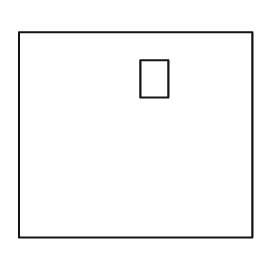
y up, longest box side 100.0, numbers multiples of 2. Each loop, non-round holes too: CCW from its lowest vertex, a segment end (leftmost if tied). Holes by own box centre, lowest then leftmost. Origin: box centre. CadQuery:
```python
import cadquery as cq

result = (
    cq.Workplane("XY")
    .moveTo(-50.0, -44.0)
    .lineTo(50.0, -44.0)
    .lineTo(50.0, 44.0)
    .lineTo(-50.0, 44.0)
    .close()
    .moveTo(2.0, 16.0)
    .lineTo(14.0, 16.0)
    .lineTo(14.0, 32.0)
    .lineTo(2.0, 32.0)
    .close()
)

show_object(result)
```